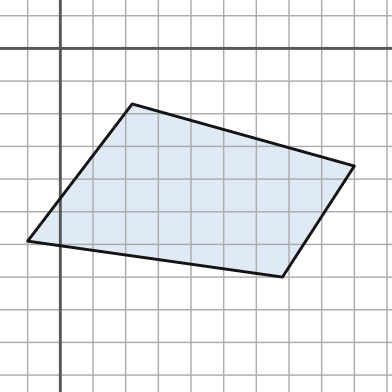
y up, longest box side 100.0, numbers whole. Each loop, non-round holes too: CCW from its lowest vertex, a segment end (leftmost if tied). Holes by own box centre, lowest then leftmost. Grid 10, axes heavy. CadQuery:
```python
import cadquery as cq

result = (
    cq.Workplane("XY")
    .moveTo(68.0, -70.0)
    .lineTo(90.0, -36.0)
    .lineTo(22.0, -17.0)
    .lineTo(-10.0, -59.0)
    .close()
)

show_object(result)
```